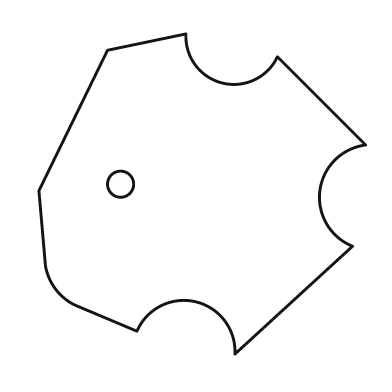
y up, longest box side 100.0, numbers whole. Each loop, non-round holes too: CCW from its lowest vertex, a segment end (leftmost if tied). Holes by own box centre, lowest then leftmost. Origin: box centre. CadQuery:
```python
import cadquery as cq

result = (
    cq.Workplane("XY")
    .moveTo(10.0, -49.0)
    .lineTo(46.0, -16.0)
    .threePointArc((36.0, 1.0), (50.0, 15.0))
    .lineTo(23.0, 42.0)
    .threePointArc((6.0, 34.0), (-5.0, 49.0))
    .lineTo(-29.0, 44.0)
    .lineTo(-50.0, 1.0)
    .lineTo(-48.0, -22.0)
    .threePointArc((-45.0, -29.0), (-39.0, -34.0))
    .lineTo(-20.0, -42.0)
    .threePointArc((-2.0, -33.0), (10.0, -49.0))
    .close()
    .moveTo(-25.0, 3.0)
    .circle(4.0)
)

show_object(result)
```